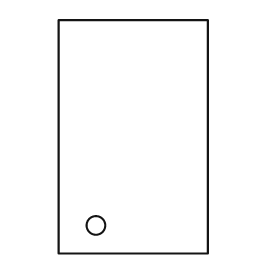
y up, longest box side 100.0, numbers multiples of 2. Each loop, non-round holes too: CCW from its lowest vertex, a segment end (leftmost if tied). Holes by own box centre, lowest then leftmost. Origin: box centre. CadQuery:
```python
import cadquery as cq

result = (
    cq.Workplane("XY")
    .moveTo(-32.0, -50.0)
    .lineTo(32.0, -50.0)
    .lineTo(32.0, 50.0)
    .lineTo(-32.0, 50.0)
    .close()
    .moveTo(-16.0, -38.0)
    .circle(4.0)
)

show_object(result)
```